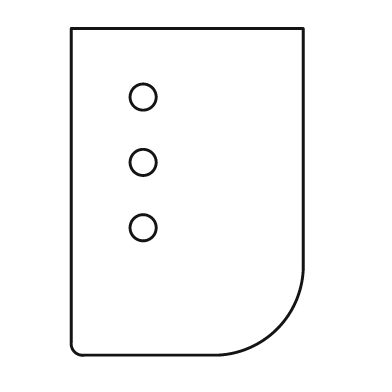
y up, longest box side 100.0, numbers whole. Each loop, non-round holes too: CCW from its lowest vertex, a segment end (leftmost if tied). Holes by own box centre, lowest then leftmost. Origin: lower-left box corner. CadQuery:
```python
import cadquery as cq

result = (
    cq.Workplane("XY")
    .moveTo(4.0, 0.0)
    .lineTo(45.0, 0.0)
    .threePointArc((63.0, 8.0), (71.0, 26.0))
    .lineTo(71.0, 100.0)
    .lineTo(0.0, 100.0)
    .lineTo(0.0, 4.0)
    .threePointArc((1.0, 1.0), (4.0, 0.0))
    .close()
    .moveTo(22.0, 39.0)
    .circle(4.0)
    .moveTo(22.0, 59.0)
    .circle(4.0)
    .moveTo(22.0, 79.0)
    .circle(4.0)
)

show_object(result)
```